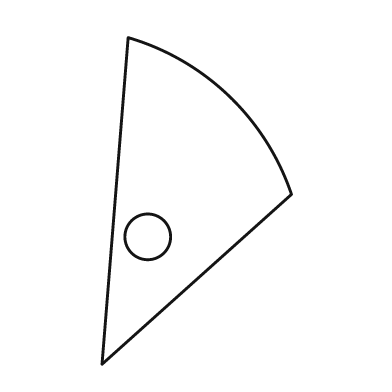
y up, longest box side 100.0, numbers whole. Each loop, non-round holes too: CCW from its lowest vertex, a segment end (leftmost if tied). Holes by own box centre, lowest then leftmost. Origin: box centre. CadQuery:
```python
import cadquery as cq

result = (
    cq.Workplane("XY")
    .moveTo(-29.0, -50.0)
    .lineTo(29.0, 2.0)
    .threePointArc((10.0, 32.0), (-21.0, 50.0))
    .close()
    .moveTo(-15.0, -11.0)
    .circle(7.0)
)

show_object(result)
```